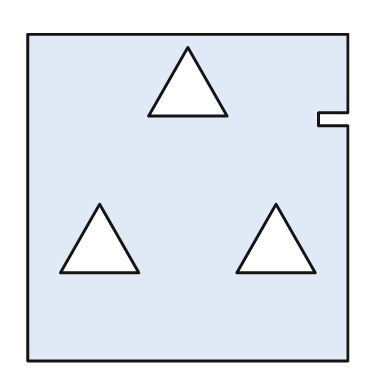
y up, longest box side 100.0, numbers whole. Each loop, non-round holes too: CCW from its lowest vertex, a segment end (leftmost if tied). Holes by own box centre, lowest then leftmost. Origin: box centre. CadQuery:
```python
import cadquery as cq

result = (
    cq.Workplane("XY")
    .moveTo(-49.0, -50.0)
    .lineTo(49.0, -50.0)
    .lineTo(49.0, 22.0)
    .lineTo(40.0, 22.0)
    .lineTo(40.0, 26.0)
    .lineTo(49.0, 26.0)
    .lineTo(49.0, 50.0)
    .lineTo(-49.0, 50.0)
    .close()
    .moveTo(-39.0, -23.0)
    .lineTo(-15.0, -23.0)
    .lineTo(-27.0, -2.0)
    .close()
    .moveTo(15.0, -23.0)
    .lineTo(39.0, -23.0)
    .lineTo(27.0, -2.0)
    .close()
    .moveTo(-12.0, 25.0)
    .lineTo(12.0, 25.0)
    .lineTo(0.0, 46.0)
    .close()
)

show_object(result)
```